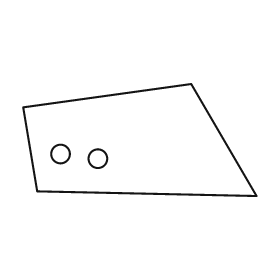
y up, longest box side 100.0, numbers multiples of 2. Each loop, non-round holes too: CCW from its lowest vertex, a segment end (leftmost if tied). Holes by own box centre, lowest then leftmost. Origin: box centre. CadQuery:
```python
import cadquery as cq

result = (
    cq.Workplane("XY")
    .moveTo(50.0, -24.0)
    .lineTo(22.0, 24.0)
    .lineTo(-50.0, 14.0)
    .lineTo(-44.0, -22.0)
    .close()
    .moveTo(-18.0, -8.0)
    .circle(4.0)
    .moveTo(-34.0, -6.0)
    .circle(4.0)
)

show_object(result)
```